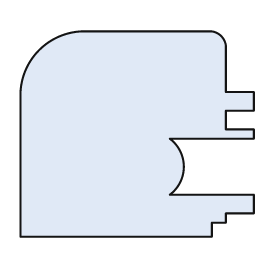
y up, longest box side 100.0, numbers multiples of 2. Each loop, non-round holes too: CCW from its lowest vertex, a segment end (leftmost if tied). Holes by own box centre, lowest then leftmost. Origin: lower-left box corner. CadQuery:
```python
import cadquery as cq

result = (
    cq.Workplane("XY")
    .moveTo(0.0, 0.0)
    .lineTo(82.0, 0.0)
    .lineTo(82.0, 6.0)
    .lineTo(88.0, 6.0)
    .lineTo(88.0, 10.0)
    .lineTo(100.0, 10.0)
    .lineTo(100.0, 18.0)
    .lineTo(64.0, 18.0)
    .threePointArc((70.0, 30.0), (64.0, 42.0))
    .lineTo(100.0, 42.0)
    .lineTo(100.0, 46.0)
    .lineTo(88.0, 46.0)
    .lineTo(88.0, 54.0)
    .lineTo(100.0, 54.0)
    .lineTo(100.0, 62.0)
    .lineTo(88.0, 62.0)
    .lineTo(88.0, 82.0)
    .threePointArc((86.0, 86.0), (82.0, 88.0))
    .lineTo(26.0, 88.0)
    .threePointArc((8.0, 80.0), (0.0, 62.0))
    .close()
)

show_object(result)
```